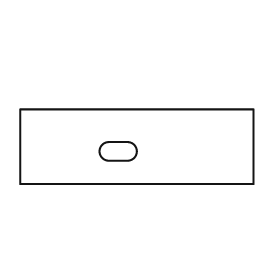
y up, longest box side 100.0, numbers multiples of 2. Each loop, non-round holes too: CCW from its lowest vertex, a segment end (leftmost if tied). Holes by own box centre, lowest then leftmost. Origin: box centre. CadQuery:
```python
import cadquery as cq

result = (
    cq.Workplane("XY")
    .moveTo(-50.0, -16.0)
    .lineTo(50.0, -16.0)
    .lineTo(50.0, 16.0)
    .lineTo(-50.0, 16.0)
    .close()
    .moveTo(-12.0, -6.0)
    .lineTo(-4.0, -6.0)
    .threePointArc((0.0, -2.0), (-4.0, 2.0))
    .lineTo(-12.0, 2.0)
    .threePointArc((-16.0, -2.0), (-12.0, -6.0))
    .close()
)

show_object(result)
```